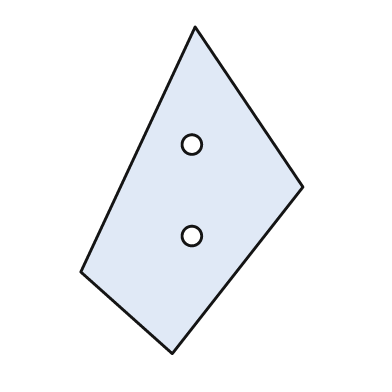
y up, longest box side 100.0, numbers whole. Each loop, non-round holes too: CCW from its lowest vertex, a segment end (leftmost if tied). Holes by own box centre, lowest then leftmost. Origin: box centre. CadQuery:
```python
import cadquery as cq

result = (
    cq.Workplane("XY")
    .moveTo(-6.0, -50.0)
    .lineTo(34.0, 1.0)
    .lineTo(1.0, 50.0)
    .lineTo(-34.0, -25.0)
    .close()
    .moveTo(0.0, -14.0)
    .circle(3.0)
    .moveTo(0.0, 14.0)
    .circle(3.0)
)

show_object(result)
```